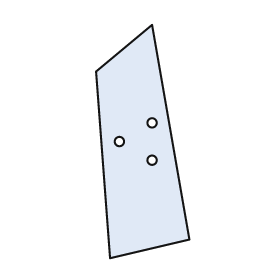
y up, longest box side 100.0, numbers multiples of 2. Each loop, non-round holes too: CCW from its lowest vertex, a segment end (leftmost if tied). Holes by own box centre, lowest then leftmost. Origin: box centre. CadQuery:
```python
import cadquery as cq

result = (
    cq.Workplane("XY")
    .moveTo(-14.0, -50.0)
    .lineTo(20.0, -42.0)
    .lineTo(4.0, 50.0)
    .lineTo(-20.0, 30.0)
    .close()
    .moveTo(4.0, -8.0)
    .circle(2.0)
    .moveTo(-10.0, 0.0)
    .circle(2.0)
    .moveTo(4.0, 8.0)
    .circle(2.0)
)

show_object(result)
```